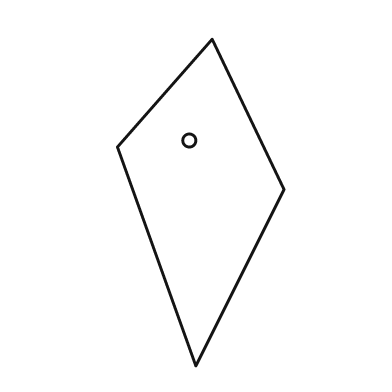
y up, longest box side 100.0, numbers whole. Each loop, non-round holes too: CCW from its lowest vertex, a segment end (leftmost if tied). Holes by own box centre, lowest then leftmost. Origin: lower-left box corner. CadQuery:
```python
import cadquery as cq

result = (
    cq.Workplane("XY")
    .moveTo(24.0, 0.0)
    .lineTo(51.0, 54.0)
    .lineTo(29.0, 100.0)
    .lineTo(0.0, 67.0)
    .close()
    .moveTo(22.0, 69.0)
    .circle(2.0)
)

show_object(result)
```